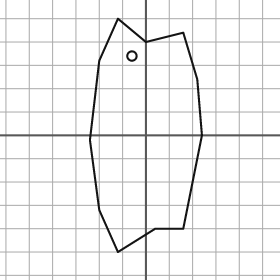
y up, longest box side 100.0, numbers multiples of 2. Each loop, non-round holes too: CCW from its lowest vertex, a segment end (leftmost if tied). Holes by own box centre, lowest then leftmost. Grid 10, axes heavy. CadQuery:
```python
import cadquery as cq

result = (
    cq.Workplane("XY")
    .moveTo(-12.0, -50.0)
    .lineTo(4.0, -40.0)
    .lineTo(16.0, -40.0)
    .lineTo(24.0, 0.0)
    .lineTo(22.0, 24.0)
    .lineTo(16.0, 44.0)
    .lineTo(0.0, 40.0)
    .lineTo(-12.0, 50.0)
    .lineTo(-20.0, 32.0)
    .lineTo(-24.0, -2.0)
    .lineTo(-20.0, -32.0)
    .close()
    .moveTo(-6.0, 34.0)
    .circle(2.0)
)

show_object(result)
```